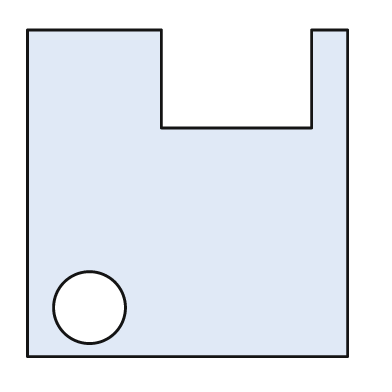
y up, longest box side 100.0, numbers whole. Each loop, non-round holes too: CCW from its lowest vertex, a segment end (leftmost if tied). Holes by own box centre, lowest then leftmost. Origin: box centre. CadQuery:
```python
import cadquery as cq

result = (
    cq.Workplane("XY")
    .moveTo(-49.0, -50.0)
    .lineTo(49.0, -50.0)
    .lineTo(49.0, 50.0)
    .lineTo(38.0, 50.0)
    .lineTo(38.0, 20.0)
    .lineTo(-8.0, 20.0)
    .lineTo(-8.0, 50.0)
    .lineTo(-49.0, 50.0)
    .close()
    .moveTo(-30.0, -35.0)
    .circle(11.0)
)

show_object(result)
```